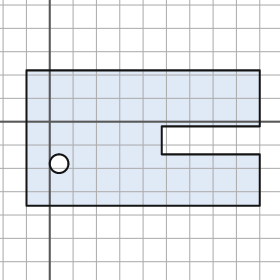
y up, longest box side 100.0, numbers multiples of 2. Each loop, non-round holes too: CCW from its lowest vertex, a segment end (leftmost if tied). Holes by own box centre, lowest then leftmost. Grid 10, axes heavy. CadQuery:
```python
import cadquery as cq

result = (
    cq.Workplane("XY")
    .moveTo(-10.0, -36.0)
    .lineTo(90.0, -36.0)
    .lineTo(90.0, -14.0)
    .lineTo(48.0, -14.0)
    .lineTo(48.0, -2.0)
    .lineTo(90.0, -2.0)
    .lineTo(90.0, 22.0)
    .lineTo(-10.0, 22.0)
    .close()
    .moveTo(4.0, -18.0)
    .circle(4.0)
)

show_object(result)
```